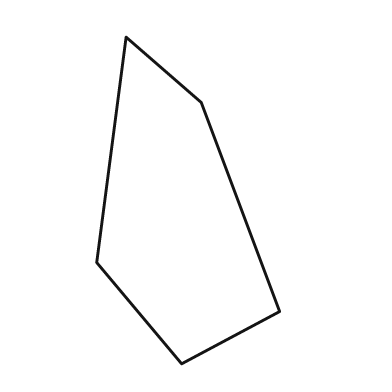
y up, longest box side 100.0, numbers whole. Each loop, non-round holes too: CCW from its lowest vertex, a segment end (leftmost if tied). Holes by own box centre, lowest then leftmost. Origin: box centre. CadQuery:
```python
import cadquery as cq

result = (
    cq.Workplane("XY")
    .moveTo(-2.0, -50.0)
    .lineTo(28.0, -34.0)
    .lineTo(4.0, 30.0)
    .lineTo(-19.0, 50.0)
    .lineTo(-28.0, -19.0)
    .close()
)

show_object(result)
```